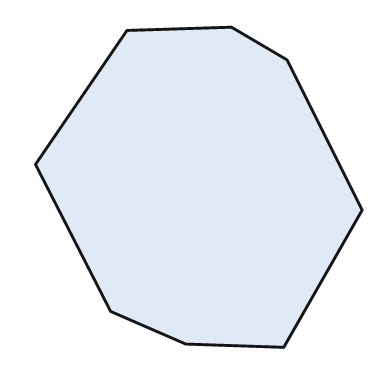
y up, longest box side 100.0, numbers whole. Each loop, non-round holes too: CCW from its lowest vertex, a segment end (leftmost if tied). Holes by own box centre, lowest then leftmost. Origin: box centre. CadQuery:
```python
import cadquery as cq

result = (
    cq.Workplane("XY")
    .moveTo(26.0, -49.0)
    .lineTo(50.0, -7.0)
    .lineTo(27.0, 39.0)
    .lineTo(10.0, 49.0)
    .lineTo(-22.0, 48.0)
    .lineTo(-50.0, 7.0)
    .lineTo(-27.0, -38.0)
    .lineTo(-4.0, -48.0)
    .close()
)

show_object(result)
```